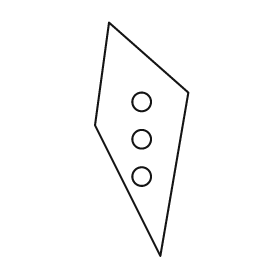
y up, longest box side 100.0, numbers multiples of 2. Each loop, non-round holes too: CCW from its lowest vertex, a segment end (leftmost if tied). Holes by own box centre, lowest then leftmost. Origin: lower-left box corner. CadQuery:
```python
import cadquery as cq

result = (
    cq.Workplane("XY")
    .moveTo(28.0, 0.0)
    .lineTo(40.0, 70.0)
    .lineTo(6.0, 100.0)
    .lineTo(0.0, 56.0)
    .close()
    .moveTo(20.0, 34.0)
    .circle(4.0)
    .moveTo(20.0, 50.0)
    .circle(4.0)
    .moveTo(20.0, 66.0)
    .circle(4.0)
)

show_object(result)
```